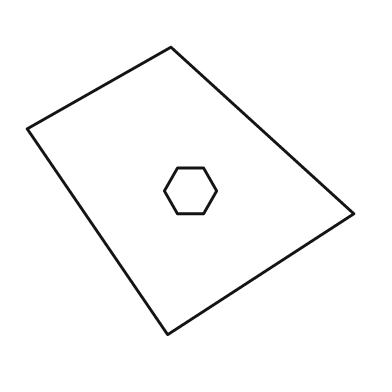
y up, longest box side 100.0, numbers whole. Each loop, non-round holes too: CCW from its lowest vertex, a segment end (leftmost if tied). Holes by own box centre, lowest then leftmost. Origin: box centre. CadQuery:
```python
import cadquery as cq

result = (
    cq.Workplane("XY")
    .moveTo(-7.0, -44.0)
    .lineTo(50.0, -7.0)
    .lineTo(-6.0, 44.0)
    .lineTo(-50.0, 19.0)
    .close()
    .moveTo(-4.0, -7.0)
    .lineTo(4.0, -7.0)
    .lineTo(8.0, 0.0)
    .lineTo(4.0, 7.0)
    .lineTo(-4.0, 7.0)
    .lineTo(-8.0, 0.0)
    .close()
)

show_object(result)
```